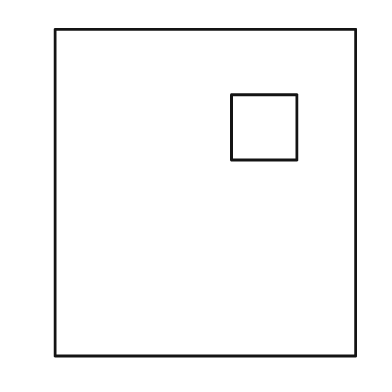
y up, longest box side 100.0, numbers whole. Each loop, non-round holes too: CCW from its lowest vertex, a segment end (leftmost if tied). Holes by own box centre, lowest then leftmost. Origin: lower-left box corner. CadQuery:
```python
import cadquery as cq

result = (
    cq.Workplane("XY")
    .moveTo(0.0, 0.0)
    .lineTo(92.0, 0.0)
    .lineTo(92.0, 100.0)
    .lineTo(0.0, 100.0)
    .close()
    .moveTo(54.0, 60.0)
    .lineTo(74.0, 60.0)
    .lineTo(74.0, 80.0)
    .lineTo(54.0, 80.0)
    .close()
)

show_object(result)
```